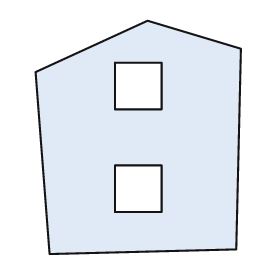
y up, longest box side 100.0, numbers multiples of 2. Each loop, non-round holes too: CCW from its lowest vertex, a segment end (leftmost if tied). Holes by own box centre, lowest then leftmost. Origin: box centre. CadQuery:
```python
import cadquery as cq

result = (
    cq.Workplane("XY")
    .moveTo(-38.0, -50.0)
    .lineTo(42.0, -48.0)
    .lineTo(44.0, 38.0)
    .lineTo(4.0, 50.0)
    .lineTo(-44.0, 28.0)
    .close()
    .moveTo(-10.0, -32.0)
    .lineTo(10.0, -32.0)
    .lineTo(10.0, -12.0)
    .lineTo(-10.0, -12.0)
    .close()
    .moveTo(-10.0, 12.0)
    .lineTo(10.0, 12.0)
    .lineTo(10.0, 32.0)
    .lineTo(-10.0, 32.0)
    .close()
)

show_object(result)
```